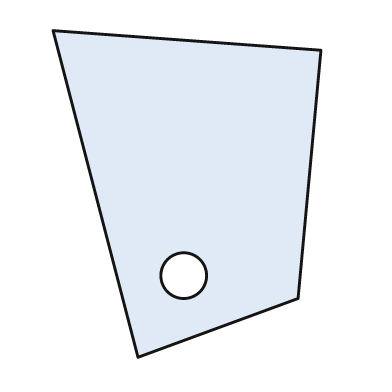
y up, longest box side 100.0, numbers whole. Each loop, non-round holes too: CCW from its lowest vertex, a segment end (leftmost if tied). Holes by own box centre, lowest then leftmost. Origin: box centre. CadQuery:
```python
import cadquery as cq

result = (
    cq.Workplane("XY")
    .moveTo(-15.0, -50.0)
    .lineTo(34.0, -32.0)
    .lineTo(41.0, 44.0)
    .lineTo(-41.0, 50.0)
    .close()
    .moveTo(-1.0, -25.0)
    .circle(7.0)
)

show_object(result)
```